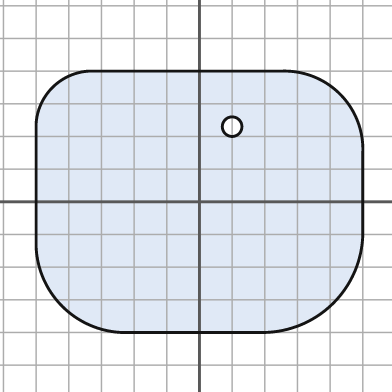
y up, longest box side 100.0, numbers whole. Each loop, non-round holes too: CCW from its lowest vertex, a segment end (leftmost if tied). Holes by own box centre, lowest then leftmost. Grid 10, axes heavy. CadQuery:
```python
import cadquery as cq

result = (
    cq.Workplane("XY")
    .moveTo(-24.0, -40.0)
    .lineTo(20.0, -40.0)
    .threePointArc((41.0, -31.0), (50.0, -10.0))
    .lineTo(50.0, 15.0)
    .threePointArc((43.0, 33.0), (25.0, 40.0))
    .lineTo(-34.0, 40.0)
    .threePointArc((-45.0, 35.0), (-50.0, 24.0))
    .lineTo(-50.0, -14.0)
    .threePointArc((-42.0, -32.0), (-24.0, -40.0))
    .close()
    .moveTo(10.0, 23.0)
    .circle(3.0)
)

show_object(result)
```